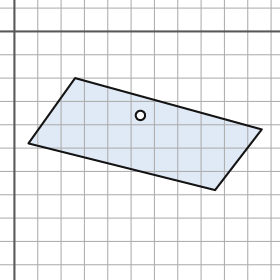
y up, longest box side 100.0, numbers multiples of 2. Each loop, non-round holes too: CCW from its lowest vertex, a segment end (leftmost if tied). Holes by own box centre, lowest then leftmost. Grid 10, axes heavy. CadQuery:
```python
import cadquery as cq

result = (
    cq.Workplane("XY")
    .moveTo(86.0, -68.0)
    .lineTo(106.0, -42.0)
    .lineTo(26.0, -20.0)
    .lineTo(6.0, -48.0)
    .close()
    .moveTo(54.0, -36.0)
    .circle(2.0)
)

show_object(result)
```